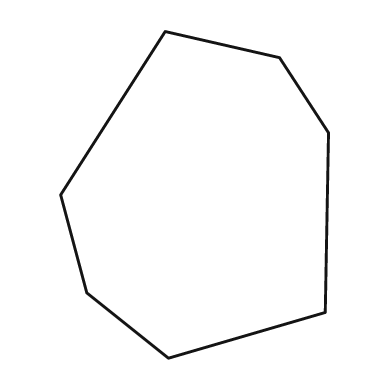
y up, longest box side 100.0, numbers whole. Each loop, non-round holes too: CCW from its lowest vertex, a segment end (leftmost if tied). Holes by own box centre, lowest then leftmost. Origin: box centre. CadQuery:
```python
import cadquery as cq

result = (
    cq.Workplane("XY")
    .moveTo(-8.0, -50.0)
    .lineTo(40.0, -36.0)
    .lineTo(41.0, 19.0)
    .lineTo(26.0, 42.0)
    .lineTo(-9.0, 50.0)
    .lineTo(-41.0, 0.0)
    .lineTo(-33.0, -30.0)
    .close()
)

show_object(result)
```